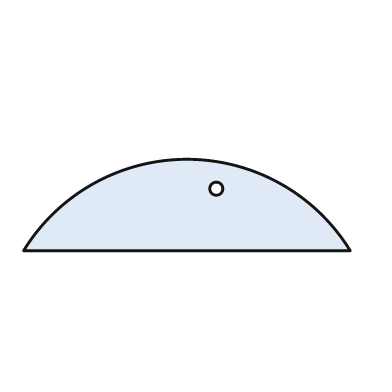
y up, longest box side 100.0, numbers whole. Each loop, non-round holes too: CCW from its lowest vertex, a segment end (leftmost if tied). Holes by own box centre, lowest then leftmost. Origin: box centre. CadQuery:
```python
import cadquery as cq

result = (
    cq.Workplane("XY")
    .moveTo(-50.0, -14.0)
    .lineTo(50.0, -14.0)
    .threePointArc((0.0, 14.0), (-50.0, -14.0))
    .close()
    .moveTo(9.0, 5.0)
    .circle(2.0)
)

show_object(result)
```